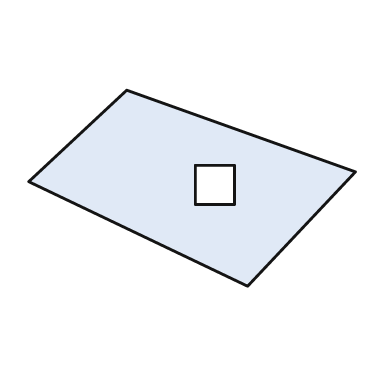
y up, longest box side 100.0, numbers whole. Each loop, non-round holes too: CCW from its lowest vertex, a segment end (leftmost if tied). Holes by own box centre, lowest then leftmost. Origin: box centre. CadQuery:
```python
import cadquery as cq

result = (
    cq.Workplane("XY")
    .moveTo(17.0, -30.0)
    .lineTo(50.0, 5.0)
    .lineTo(-20.0, 30.0)
    .lineTo(-50.0, 2.0)
    .close()
    .moveTo(1.0, -5.0)
    .lineTo(13.0, -5.0)
    .lineTo(13.0, 7.0)
    .lineTo(1.0, 7.0)
    .close()
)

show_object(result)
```